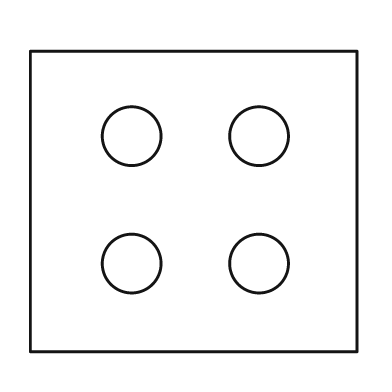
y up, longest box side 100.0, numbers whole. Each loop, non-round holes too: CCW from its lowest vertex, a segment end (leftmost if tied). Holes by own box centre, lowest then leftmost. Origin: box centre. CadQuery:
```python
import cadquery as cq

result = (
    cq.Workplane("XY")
    .moveTo(-50.0, -46.0)
    .lineTo(50.0, -46.0)
    .lineTo(50.0, 46.0)
    .lineTo(-50.0, 46.0)
    .close()
    .moveTo(-19.0, -19.0)
    .circle(9.0)
    .moveTo(20.0, -19.0)
    .circle(9.0)
    .moveTo(-19.0, 20.0)
    .circle(9.0)
    .moveTo(20.0, 20.0)
    .circle(9.0)
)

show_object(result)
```